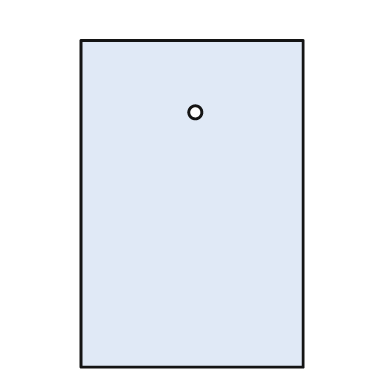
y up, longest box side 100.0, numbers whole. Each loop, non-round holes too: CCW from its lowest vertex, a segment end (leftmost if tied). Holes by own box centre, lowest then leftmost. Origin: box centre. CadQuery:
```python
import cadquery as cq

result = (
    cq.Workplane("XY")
    .moveTo(-34.0, -50.0)
    .lineTo(34.0, -50.0)
    .lineTo(34.0, 50.0)
    .lineTo(-34.0, 50.0)
    .close()
    .moveTo(1.0, 28.0)
    .circle(2.0)
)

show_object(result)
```